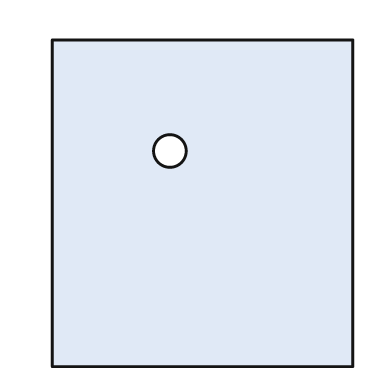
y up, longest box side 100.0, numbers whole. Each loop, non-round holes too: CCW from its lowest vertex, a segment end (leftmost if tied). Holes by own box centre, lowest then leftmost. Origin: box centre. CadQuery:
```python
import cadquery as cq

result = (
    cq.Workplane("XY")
    .moveTo(-46.0, -50.0)
    .lineTo(46.0, -50.0)
    .lineTo(46.0, 50.0)
    .lineTo(-46.0, 50.0)
    .close()
    .moveTo(-10.0, 16.0)
    .circle(5.0)
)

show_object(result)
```